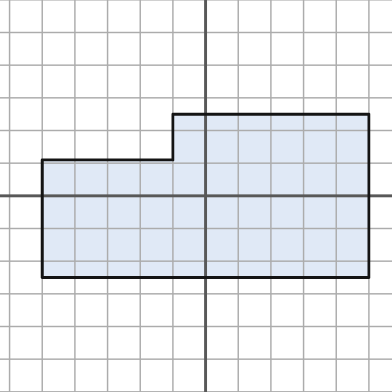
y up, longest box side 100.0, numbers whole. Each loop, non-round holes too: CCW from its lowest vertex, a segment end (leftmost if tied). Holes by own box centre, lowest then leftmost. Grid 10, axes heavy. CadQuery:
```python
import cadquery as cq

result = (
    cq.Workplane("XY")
    .moveTo(-50.0, -25.0)
    .lineTo(50.0, -25.0)
    .lineTo(50.0, 25.0)
    .lineTo(-10.0, 25.0)
    .lineTo(-10.0, 11.0)
    .lineTo(-50.0, 11.0)
    .close()
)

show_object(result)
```